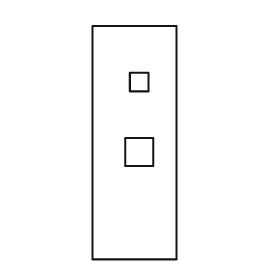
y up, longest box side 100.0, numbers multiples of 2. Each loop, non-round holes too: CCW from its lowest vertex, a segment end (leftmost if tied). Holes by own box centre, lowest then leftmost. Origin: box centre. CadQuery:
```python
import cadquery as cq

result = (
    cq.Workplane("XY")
    .moveTo(-18.0, -50.0)
    .lineTo(18.0, -50.0)
    .lineTo(18.0, 50.0)
    .lineTo(-18.0, 50.0)
    .close()
    .moveTo(-4.0, -10.0)
    .lineTo(8.0, -10.0)
    .lineTo(8.0, 2.0)
    .lineTo(-4.0, 2.0)
    .close()
    .moveTo(-2.0, 22.0)
    .lineTo(6.0, 22.0)
    .lineTo(6.0, 30.0)
    .lineTo(-2.0, 30.0)
    .close()
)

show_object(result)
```